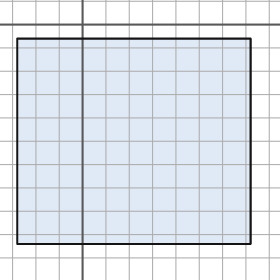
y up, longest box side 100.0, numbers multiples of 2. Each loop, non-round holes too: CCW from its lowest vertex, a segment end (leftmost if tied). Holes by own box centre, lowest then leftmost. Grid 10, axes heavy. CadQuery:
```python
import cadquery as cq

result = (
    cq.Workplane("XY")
    .moveTo(-28.0, -94.0)
    .lineTo(72.0, -94.0)
    .lineTo(72.0, -6.0)
    .lineTo(-28.0, -6.0)
    .close()
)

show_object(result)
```